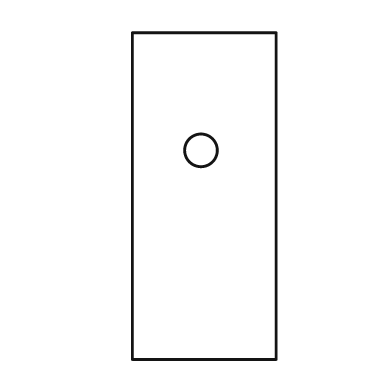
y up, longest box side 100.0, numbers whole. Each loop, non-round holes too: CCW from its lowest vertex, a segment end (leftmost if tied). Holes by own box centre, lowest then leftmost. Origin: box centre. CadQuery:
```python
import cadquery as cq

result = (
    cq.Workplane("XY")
    .moveTo(-22.0, -50.0)
    .lineTo(22.0, -50.0)
    .lineTo(22.0, 50.0)
    .lineTo(-22.0, 50.0)
    .close()
    .moveTo(-1.0, 14.0)
    .circle(5.0)
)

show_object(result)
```